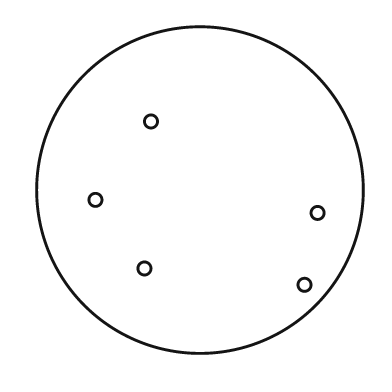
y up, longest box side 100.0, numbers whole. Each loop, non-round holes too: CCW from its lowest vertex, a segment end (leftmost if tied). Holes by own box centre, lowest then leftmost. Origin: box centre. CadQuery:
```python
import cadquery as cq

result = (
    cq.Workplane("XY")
    .moveTo(0.0, 0.0)
    .circle(50.0)
    .moveTo(32.0, -29.0)
    .circle(2.0)
    .moveTo(-17.0, -24.0)
    .circle(2.0)
    .moveTo(36.0, -7.0)
    .circle(2.0)
    .moveTo(-32.0, -3.0)
    .circle(2.0)
    .moveTo(-15.0, 21.0)
    .circle(2.0)
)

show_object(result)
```